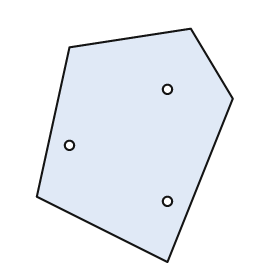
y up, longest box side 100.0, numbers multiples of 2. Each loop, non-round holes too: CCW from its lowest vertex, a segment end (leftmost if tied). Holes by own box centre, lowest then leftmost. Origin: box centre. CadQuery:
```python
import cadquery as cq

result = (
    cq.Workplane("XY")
    .moveTo(14.0, -50.0)
    .lineTo(42.0, 20.0)
    .lineTo(24.0, 50.0)
    .lineTo(-28.0, 42.0)
    .lineTo(-42.0, -22.0)
    .close()
    .moveTo(14.0, -24.0)
    .circle(2.0)
    .moveTo(-28.0, 0.0)
    .circle(2.0)
    .moveTo(14.0, 24.0)
    .circle(2.0)
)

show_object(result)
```